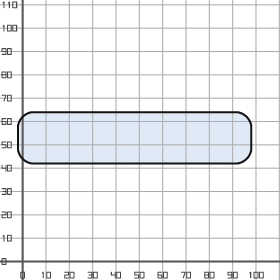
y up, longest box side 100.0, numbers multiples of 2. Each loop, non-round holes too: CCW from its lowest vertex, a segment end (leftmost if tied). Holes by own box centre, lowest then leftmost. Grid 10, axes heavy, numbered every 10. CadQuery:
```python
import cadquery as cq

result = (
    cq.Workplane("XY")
    .moveTo(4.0, 42.0)
    .lineTo(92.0, 42.0)
    .threePointArc((96.0, 44.0), (98.0, 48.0))
    .lineTo(98.0, 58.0)
    .threePointArc((96.0, 62.0), (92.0, 64.0))
    .lineTo(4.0, 64.0)
    .threePointArc((0.0, 62.0), (-2.0, 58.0))
    .lineTo(-2.0, 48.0)
    .threePointArc((0.0, 44.0), (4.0, 42.0))
    .close()
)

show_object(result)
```